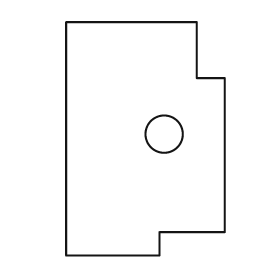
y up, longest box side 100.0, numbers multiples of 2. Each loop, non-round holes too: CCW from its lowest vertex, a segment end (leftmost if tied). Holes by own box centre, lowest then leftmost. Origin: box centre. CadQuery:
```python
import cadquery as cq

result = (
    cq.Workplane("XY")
    .moveTo(-34.0, -50.0)
    .lineTo(6.0, -50.0)
    .lineTo(6.0, -40.0)
    .lineTo(34.0, -40.0)
    .lineTo(34.0, 26.0)
    .lineTo(22.0, 26.0)
    .lineTo(22.0, 50.0)
    .lineTo(-34.0, 50.0)
    .close()
    .moveTo(8.0, 2.0)
    .circle(8.0)
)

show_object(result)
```